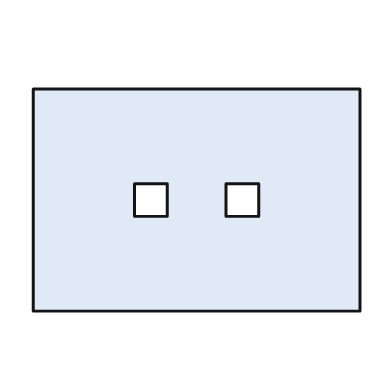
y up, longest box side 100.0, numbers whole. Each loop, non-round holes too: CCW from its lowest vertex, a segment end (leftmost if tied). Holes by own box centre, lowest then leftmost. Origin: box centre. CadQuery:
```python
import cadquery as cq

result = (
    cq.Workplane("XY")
    .moveTo(-50.0, -34.0)
    .lineTo(50.0, -34.0)
    .lineTo(50.0, 34.0)
    .lineTo(-50.0, 34.0)
    .close()
    .moveTo(-19.0, -5.0)
    .lineTo(-9.0, -5.0)
    .lineTo(-9.0, 5.0)
    .lineTo(-19.0, 5.0)
    .close()
    .moveTo(9.0, -5.0)
    .lineTo(19.0, -5.0)
    .lineTo(19.0, 5.0)
    .lineTo(9.0, 5.0)
    .close()
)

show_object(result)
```